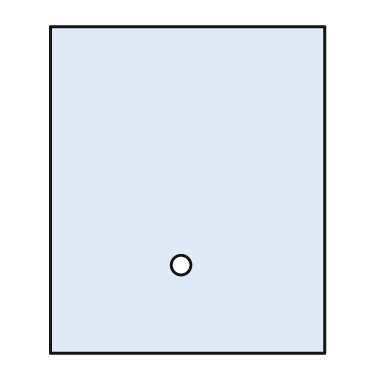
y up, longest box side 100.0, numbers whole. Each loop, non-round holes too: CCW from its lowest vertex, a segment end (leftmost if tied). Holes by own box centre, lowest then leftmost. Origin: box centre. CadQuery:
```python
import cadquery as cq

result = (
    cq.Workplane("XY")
    .moveTo(-42.0, -50.0)
    .lineTo(42.0, -50.0)
    .lineTo(42.0, 50.0)
    .lineTo(-42.0, 50.0)
    .close()
    .moveTo(-2.0, -23.0)
    .circle(3.0)
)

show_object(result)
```